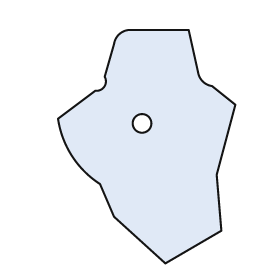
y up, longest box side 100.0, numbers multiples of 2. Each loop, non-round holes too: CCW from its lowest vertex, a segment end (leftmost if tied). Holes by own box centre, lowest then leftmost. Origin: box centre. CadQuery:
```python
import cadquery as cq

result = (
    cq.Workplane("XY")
    .moveTo(8.0, -50.0)
    .lineTo(32.0, -36.0)
    .lineTo(30.0, -12.0)
    .lineTo(38.0, 18.0)
    .lineTo(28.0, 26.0)
    .threePointArc((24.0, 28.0), (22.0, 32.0))
    .lineTo(18.0, 50.0)
    .lineTo(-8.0, 50.0)
    .threePointArc((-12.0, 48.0), (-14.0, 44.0))
    .lineTo(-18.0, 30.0)
    .threePointArc((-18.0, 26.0), (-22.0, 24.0))
    .lineTo(-38.0, 12.0)
    .threePointArc((-32.0, -4.0), (-20.0, -16.0))
    .lineTo(-14.0, -30.0)
    .close()
    .moveTo(-2.0, 10.0)
    .circle(4.0)
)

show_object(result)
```